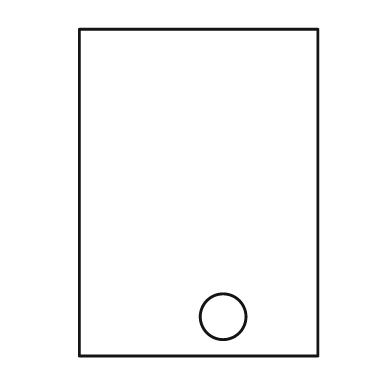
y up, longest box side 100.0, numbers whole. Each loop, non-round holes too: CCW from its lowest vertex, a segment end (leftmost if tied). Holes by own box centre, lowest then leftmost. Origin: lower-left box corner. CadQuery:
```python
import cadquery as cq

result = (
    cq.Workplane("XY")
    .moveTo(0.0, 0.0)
    .lineTo(73.0, 0.0)
    .lineTo(73.0, 100.0)
    .lineTo(0.0, 100.0)
    .close()
    .moveTo(44.0, 12.0)
    .circle(7.0)
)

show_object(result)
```